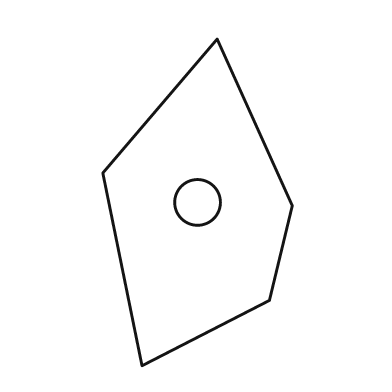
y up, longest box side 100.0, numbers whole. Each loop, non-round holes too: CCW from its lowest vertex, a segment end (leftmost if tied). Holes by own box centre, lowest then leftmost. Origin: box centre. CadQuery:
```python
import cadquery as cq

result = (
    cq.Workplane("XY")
    .moveTo(-17.0, -50.0)
    .lineTo(22.0, -30.0)
    .lineTo(29.0, -1.0)
    .lineTo(6.0, 50.0)
    .lineTo(-29.0, 9.0)
    .close()
    .moveTo(0.0, 0.0)
    .circle(7.0)
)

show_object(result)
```